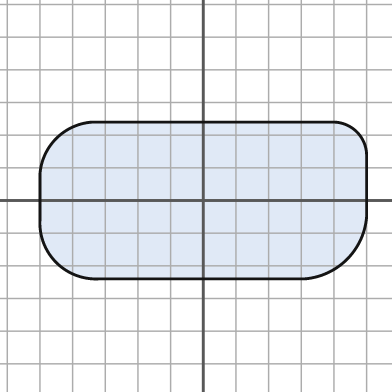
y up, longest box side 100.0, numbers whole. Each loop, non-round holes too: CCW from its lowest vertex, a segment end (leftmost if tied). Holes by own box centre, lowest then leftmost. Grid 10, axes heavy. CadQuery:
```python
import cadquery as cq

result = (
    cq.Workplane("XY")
    .moveTo(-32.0, -24.0)
    .lineTo(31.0, -24.0)
    .threePointArc((44.0, -18.0), (50.0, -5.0))
    .lineTo(50.0, 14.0)
    .threePointArc((47.0, 21.0), (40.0, 24.0))
    .lineTo(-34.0, 24.0)
    .threePointArc((-45.0, 19.0), (-50.0, 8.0))
    .lineTo(-50.0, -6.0)
    .threePointArc((-45.0, -19.0), (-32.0, -24.0))
    .close()
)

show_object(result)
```